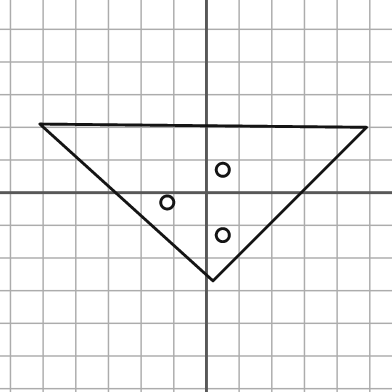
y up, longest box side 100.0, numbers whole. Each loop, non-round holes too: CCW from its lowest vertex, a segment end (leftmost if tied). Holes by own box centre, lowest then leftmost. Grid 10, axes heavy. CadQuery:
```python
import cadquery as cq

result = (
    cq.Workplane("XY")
    .moveTo(2.0, -27.0)
    .lineTo(49.0, 20.0)
    .lineTo(-51.0, 21.0)
    .close()
    .moveTo(5.0, -13.0)
    .circle(2.0)
    .moveTo(-12.0, -3.0)
    .circle(2.0)
    .moveTo(5.0, 7.0)
    .circle(2.0)
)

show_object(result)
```